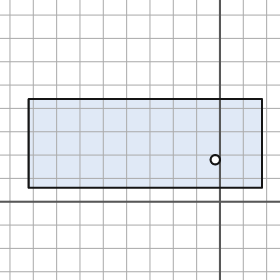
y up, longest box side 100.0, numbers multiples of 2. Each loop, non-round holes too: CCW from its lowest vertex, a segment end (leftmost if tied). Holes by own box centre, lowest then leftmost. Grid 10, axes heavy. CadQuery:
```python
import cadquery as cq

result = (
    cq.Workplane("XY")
    .moveTo(-82.0, 6.0)
    .lineTo(18.0, 6.0)
    .lineTo(18.0, 44.0)
    .lineTo(-82.0, 44.0)
    .close()
    .moveTo(-2.0, 18.0)
    .circle(2.0)
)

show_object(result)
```